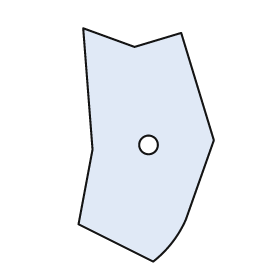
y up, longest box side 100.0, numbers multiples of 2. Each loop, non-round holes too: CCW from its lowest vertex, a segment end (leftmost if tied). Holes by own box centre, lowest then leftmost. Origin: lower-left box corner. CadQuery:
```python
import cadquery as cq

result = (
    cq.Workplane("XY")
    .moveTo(32.0, 0.0)
    .threePointArc((40.0, 8.0), (46.0, 18.0))
    .lineTo(58.0, 52.0)
    .lineTo(44.0, 98.0)
    .lineTo(24.0, 92.0)
    .lineTo(2.0, 100.0)
    .lineTo(6.0, 48.0)
    .lineTo(0.0, 16.0)
    .close()
    .moveTo(30.0, 50.0)
    .circle(4.0)
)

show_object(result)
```